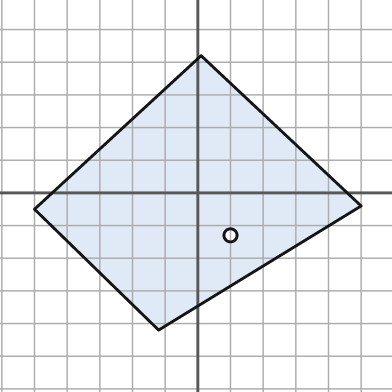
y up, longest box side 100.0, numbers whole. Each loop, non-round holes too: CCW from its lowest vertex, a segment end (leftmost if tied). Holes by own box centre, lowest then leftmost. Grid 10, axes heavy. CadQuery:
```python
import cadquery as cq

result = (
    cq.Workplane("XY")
    .moveTo(-12.0, -42.0)
    .lineTo(50.0, -4.0)
    .lineTo(1.0, 42.0)
    .lineTo(-50.0, -5.0)
    .close()
    .moveTo(10.0, -13.0)
    .circle(2.0)
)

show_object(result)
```